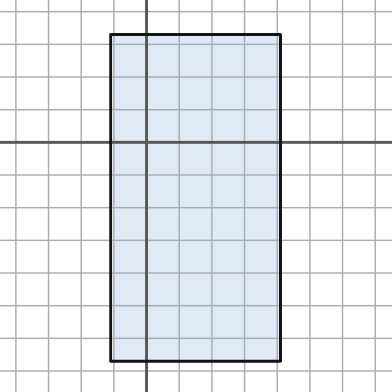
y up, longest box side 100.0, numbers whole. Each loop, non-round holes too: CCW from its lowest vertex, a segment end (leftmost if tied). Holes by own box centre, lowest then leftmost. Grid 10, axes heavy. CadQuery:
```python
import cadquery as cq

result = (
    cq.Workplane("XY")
    .moveTo(-11.0, -67.0)
    .lineTo(41.0, -67.0)
    .lineTo(41.0, 33.0)
    .lineTo(-11.0, 33.0)
    .close()
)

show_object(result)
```